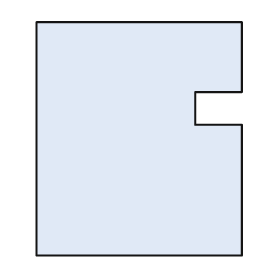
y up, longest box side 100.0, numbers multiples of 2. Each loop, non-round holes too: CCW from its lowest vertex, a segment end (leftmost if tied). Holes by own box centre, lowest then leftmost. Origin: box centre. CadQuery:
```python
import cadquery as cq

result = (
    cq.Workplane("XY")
    .moveTo(-44.0, -50.0)
    .lineTo(44.0, -50.0)
    .lineTo(44.0, 6.0)
    .lineTo(24.0, 6.0)
    .lineTo(24.0, 20.0)
    .lineTo(44.0, 20.0)
    .lineTo(44.0, 50.0)
    .lineTo(-44.0, 50.0)
    .close()
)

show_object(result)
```